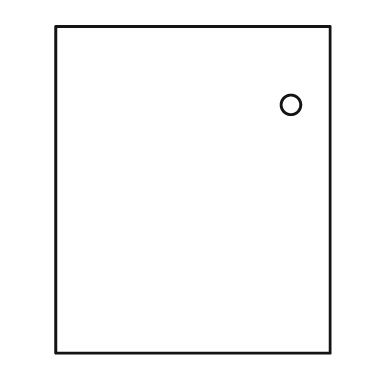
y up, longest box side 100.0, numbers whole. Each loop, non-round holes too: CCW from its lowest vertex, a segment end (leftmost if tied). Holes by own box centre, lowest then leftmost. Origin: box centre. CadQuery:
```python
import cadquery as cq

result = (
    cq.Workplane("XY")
    .moveTo(-42.0, -50.0)
    .lineTo(42.0, -50.0)
    .lineTo(42.0, 50.0)
    .lineTo(-42.0, 50.0)
    .close()
    .moveTo(30.0, 26.0)
    .circle(3.0)
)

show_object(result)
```